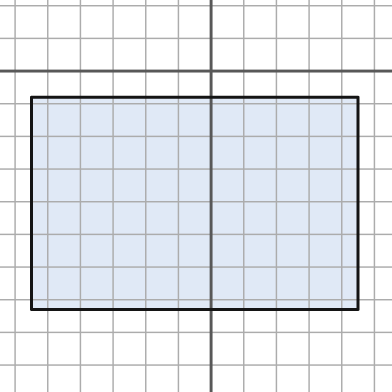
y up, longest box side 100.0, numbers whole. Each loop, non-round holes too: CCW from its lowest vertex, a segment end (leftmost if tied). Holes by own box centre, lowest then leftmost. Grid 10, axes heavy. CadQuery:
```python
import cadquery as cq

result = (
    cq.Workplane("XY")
    .moveTo(-55.0, -73.0)
    .lineTo(45.0, -73.0)
    .lineTo(45.0, -8.0)
    .lineTo(-55.0, -8.0)
    .close()
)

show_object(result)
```